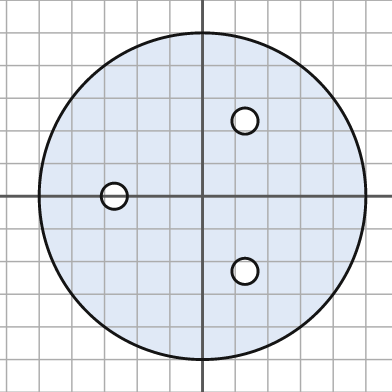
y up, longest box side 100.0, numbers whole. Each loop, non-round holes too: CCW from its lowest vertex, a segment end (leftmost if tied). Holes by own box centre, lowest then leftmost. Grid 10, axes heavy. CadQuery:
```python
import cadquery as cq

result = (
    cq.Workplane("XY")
    .moveTo(0.0, 0.0)
    .circle(50.0)
    .moveTo(13.0, -23.0)
    .circle(4.0)
    .moveTo(-27.0, 0.0)
    .circle(4.0)
    .moveTo(13.0, 23.0)
    .circle(4.0)
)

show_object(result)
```